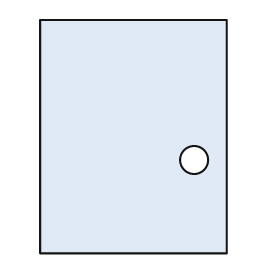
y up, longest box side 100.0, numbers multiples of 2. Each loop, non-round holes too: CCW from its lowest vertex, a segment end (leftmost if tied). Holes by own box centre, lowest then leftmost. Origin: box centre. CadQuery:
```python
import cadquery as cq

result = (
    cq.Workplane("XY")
    .moveTo(-40.0, -50.0)
    .lineTo(40.0, -50.0)
    .lineTo(40.0, 50.0)
    .lineTo(-40.0, 50.0)
    .close()
    .moveTo(26.0, -10.0)
    .circle(6.0)
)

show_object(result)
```